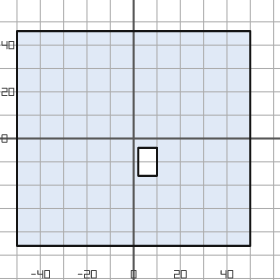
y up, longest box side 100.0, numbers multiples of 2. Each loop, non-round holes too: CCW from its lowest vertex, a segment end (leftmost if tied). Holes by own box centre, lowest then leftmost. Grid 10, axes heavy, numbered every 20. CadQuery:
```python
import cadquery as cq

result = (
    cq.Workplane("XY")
    .moveTo(-50.0, -46.0)
    .lineTo(50.0, -46.0)
    .lineTo(50.0, 46.0)
    .lineTo(-50.0, 46.0)
    .close()
    .moveTo(2.0, -16.0)
    .lineTo(10.0, -16.0)
    .lineTo(10.0, -4.0)
    .lineTo(2.0, -4.0)
    .close()
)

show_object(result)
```